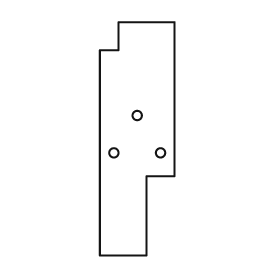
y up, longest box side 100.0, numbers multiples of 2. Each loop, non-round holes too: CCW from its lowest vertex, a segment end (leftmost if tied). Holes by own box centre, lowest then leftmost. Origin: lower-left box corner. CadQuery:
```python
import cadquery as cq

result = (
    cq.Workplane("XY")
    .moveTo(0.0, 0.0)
    .lineTo(20.0, 0.0)
    .lineTo(20.0, 34.0)
    .lineTo(32.0, 34.0)
    .lineTo(32.0, 100.0)
    .lineTo(8.0, 100.0)
    .lineTo(8.0, 88.0)
    .lineTo(0.0, 88.0)
    .close()
    .moveTo(6.0, 44.0)
    .circle(2.0)
    .moveTo(26.0, 44.0)
    .circle(2.0)
    .moveTo(16.0, 60.0)
    .circle(2.0)
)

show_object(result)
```